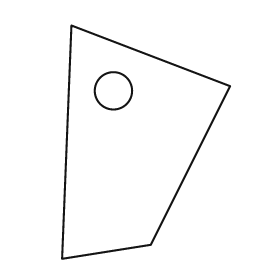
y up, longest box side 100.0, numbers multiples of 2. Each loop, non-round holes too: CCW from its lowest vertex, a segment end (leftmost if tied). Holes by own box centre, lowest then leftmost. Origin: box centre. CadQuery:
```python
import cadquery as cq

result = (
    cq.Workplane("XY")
    .moveTo(-36.0, -50.0)
    .lineTo(2.0, -44.0)
    .lineTo(36.0, 24.0)
    .lineTo(-32.0, 50.0)
    .close()
    .moveTo(-14.0, 22.0)
    .circle(8.0)
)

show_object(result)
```